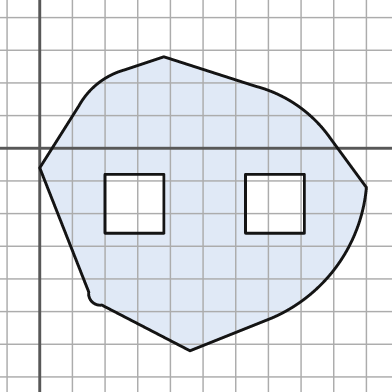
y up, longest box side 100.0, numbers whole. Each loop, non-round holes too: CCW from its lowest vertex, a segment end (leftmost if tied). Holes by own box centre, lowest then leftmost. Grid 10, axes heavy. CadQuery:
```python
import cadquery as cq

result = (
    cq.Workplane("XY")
    .moveTo(46.0, -62.0)
    .lineTo(71.0, -52.0)
    .threePointArc((91.0, -36.0), (100.0, -12.0))
    .lineTo(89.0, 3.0)
    .threePointArc((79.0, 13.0), (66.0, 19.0))
    .lineTo(38.0, 28.0)
    .lineTo(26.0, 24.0)
    .threePointArc((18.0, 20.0), (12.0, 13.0))
    .lineTo(0.0, -6.0)
    .lineTo(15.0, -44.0)
    .threePointArc((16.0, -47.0), (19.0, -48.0))
    .close()
    .moveTo(20.0, -26.0)
    .lineTo(38.0, -26.0)
    .lineTo(38.0, -8.0)
    .lineTo(20.0, -8.0)
    .close()
    .moveTo(63.0, -26.0)
    .lineTo(81.0, -26.0)
    .lineTo(81.0, -8.0)
    .lineTo(63.0, -8.0)
    .close()
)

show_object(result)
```